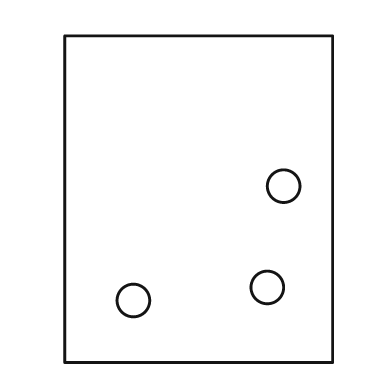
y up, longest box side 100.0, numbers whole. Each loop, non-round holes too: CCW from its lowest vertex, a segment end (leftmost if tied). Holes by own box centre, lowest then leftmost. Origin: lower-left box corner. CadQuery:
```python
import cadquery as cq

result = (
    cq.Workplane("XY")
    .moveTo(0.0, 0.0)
    .lineTo(82.0, 0.0)
    .lineTo(82.0, 100.0)
    .lineTo(0.0, 100.0)
    .close()
    .moveTo(21.0, 19.0)
    .circle(5.0)
    .moveTo(62.0, 23.0)
    .circle(5.0)
    .moveTo(67.0, 54.0)
    .circle(5.0)
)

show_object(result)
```